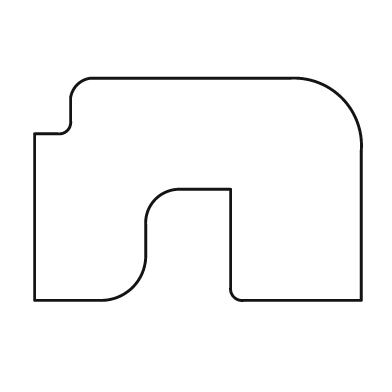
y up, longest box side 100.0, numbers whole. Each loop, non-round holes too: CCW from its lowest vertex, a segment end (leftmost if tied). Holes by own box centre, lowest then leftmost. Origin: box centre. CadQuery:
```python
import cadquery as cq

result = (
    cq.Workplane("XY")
    .moveTo(-50.0, -34.0)
    .lineTo(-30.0, -34.0)
    .threePointArc((-20.0, -30.0), (-16.0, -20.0))
    .lineTo(-16.0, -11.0)
    .threePointArc((-13.0, -3.0), (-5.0, 0.0))
    .lineTo(10.0, 0.0)
    .lineTo(10.0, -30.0)
    .threePointArc((11.0, -33.0), (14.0, -34.0))
    .lineTo(50.0, -34.0)
    .lineTo(50.0, 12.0)
    .threePointArc((44.0, 28.0), (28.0, 34.0))
    .lineTo(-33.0, 34.0)
    .threePointArc((-37.0, 32.0), (-39.0, 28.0))
    .lineTo(-39.0, 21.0)
    .threePointArc((-40.0, 18.0), (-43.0, 17.0))
    .lineTo(-50.0, 17.0)
    .close()
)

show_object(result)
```